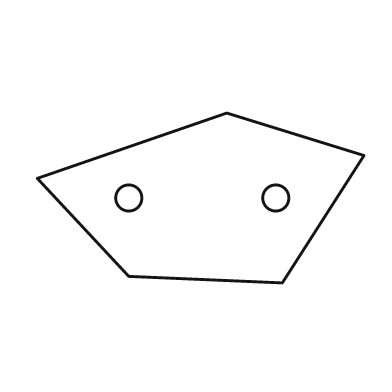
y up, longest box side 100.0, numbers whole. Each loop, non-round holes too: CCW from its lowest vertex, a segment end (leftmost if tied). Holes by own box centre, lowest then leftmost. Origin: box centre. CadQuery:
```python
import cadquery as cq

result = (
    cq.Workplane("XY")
    .moveTo(25.0, -26.0)
    .lineTo(50.0, 13.0)
    .lineTo(8.0, 26.0)
    .lineTo(-50.0, 6.0)
    .lineTo(-22.0, -24.0)
    .close()
    .moveTo(-22.0, 0.0)
    .circle(4.0)
    .moveTo(23.0, 0.0)
    .circle(4.0)
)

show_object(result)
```